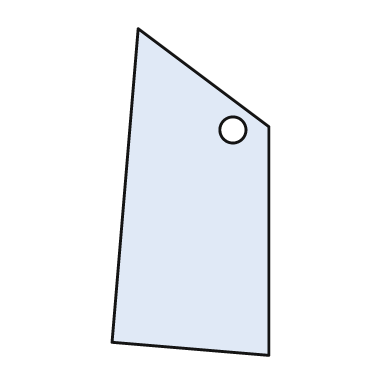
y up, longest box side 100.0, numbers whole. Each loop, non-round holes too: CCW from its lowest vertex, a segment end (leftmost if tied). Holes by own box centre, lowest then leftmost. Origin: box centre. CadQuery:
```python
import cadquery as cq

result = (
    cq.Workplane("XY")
    .moveTo(24.0, -50.0)
    .lineTo(24.0, 20.0)
    .lineTo(-16.0, 50.0)
    .lineTo(-24.0, -46.0)
    .close()
    .moveTo(13.0, 19.0)
    .circle(4.0)
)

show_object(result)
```